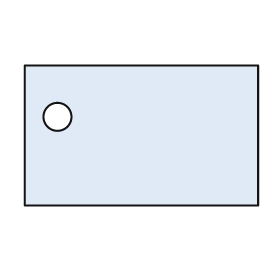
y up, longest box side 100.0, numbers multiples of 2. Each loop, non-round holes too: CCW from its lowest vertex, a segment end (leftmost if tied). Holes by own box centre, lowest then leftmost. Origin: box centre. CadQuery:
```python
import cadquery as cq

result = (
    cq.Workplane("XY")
    .moveTo(-50.0, -30.0)
    .lineTo(50.0, -30.0)
    .lineTo(50.0, 30.0)
    .lineTo(-50.0, 30.0)
    .close()
    .moveTo(-36.0, 8.0)
    .circle(6.0)
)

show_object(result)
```